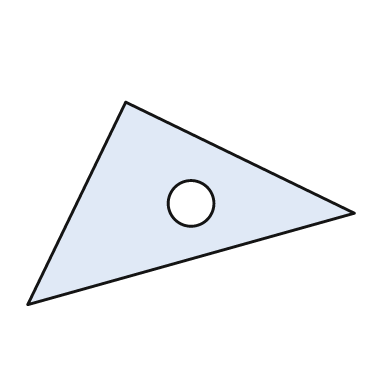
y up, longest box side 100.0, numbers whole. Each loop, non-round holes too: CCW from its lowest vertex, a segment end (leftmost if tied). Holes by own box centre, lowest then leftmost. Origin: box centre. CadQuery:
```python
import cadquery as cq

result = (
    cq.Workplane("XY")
    .moveTo(-50.0, -31.0)
    .lineTo(50.0, -3.0)
    .lineTo(-20.0, 31.0)
    .close()
    .moveTo(0.0, 0.0)
    .circle(7.0)
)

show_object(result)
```